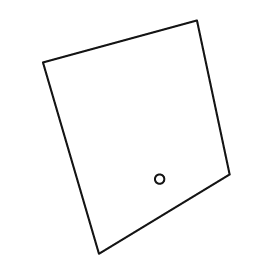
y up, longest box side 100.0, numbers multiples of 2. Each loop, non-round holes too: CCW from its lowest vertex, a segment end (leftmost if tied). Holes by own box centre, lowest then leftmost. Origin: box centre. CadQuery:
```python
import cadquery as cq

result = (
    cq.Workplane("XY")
    .moveTo(-16.0, -50.0)
    .lineTo(40.0, -16.0)
    .lineTo(26.0, 50.0)
    .lineTo(-40.0, 32.0)
    .close()
    .moveTo(10.0, -18.0)
    .circle(2.0)
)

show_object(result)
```